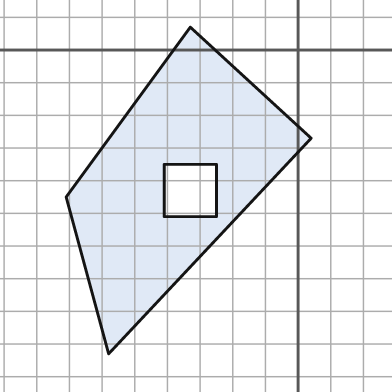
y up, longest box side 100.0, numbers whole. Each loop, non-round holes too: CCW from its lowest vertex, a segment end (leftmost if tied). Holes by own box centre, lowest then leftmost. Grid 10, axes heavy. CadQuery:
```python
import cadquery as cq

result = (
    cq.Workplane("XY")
    .moveTo(-58.0, -93.0)
    .lineTo(4.0, -27.0)
    .lineTo(-33.0, 7.0)
    .lineTo(-71.0, -45.0)
    .close()
    .moveTo(-41.0, -51.0)
    .lineTo(-25.0, -51.0)
    .lineTo(-25.0, -35.0)
    .lineTo(-41.0, -35.0)
    .close()
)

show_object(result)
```